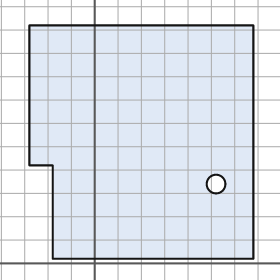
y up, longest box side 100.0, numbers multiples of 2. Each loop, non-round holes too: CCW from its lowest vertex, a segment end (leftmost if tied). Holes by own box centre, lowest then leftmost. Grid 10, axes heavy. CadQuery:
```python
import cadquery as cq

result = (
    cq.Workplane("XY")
    .moveTo(-18.0, 2.0)
    .lineTo(68.0, 2.0)
    .lineTo(68.0, 102.0)
    .lineTo(-28.0, 102.0)
    .lineTo(-28.0, 42.0)
    .lineTo(-18.0, 42.0)
    .close()
    .moveTo(52.0, 34.0)
    .circle(4.0)
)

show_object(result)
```